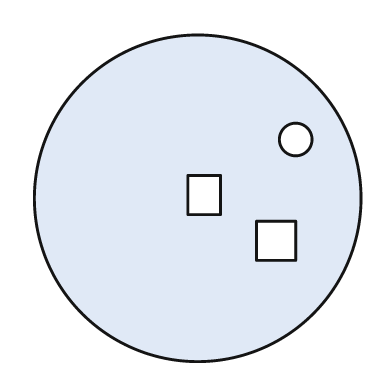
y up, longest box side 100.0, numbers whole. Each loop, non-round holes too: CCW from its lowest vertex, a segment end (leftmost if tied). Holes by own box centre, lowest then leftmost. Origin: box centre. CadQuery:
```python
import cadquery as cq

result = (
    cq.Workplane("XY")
    .moveTo(0.0, 0.0)
    .circle(50.0)
    .moveTo(18.0, -19.0)
    .lineTo(30.0, -19.0)
    .lineTo(30.0, -7.0)
    .lineTo(18.0, -7.0)
    .close()
    .moveTo(-3.0, -5.0)
    .lineTo(7.0, -5.0)
    .lineTo(7.0, 7.0)
    .lineTo(-3.0, 7.0)
    .close()
    .moveTo(30.0, 18.0)
    .circle(5.0)
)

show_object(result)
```